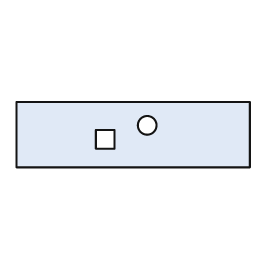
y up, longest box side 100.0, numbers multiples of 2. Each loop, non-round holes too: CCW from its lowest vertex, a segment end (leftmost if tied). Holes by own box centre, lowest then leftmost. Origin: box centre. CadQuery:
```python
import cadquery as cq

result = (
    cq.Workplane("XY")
    .moveTo(-50.0, -14.0)
    .lineTo(50.0, -14.0)
    .lineTo(50.0, 14.0)
    .lineTo(-50.0, 14.0)
    .close()
    .moveTo(-16.0, -6.0)
    .lineTo(-8.0, -6.0)
    .lineTo(-8.0, 2.0)
    .lineTo(-16.0, 2.0)
    .close()
    .moveTo(6.0, 4.0)
    .circle(4.0)
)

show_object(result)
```